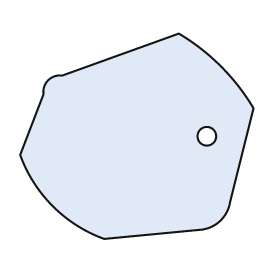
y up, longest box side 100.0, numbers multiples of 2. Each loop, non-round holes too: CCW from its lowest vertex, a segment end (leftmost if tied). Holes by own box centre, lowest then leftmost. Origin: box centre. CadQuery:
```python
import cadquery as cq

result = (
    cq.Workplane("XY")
    .moveTo(-14.0, -44.0)
    .lineTo(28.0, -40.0)
    .threePointArc((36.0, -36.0), (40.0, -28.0))
    .lineTo(50.0, 12.0)
    .threePointArc((36.0, 30.0), (18.0, 44.0))
    .lineTo(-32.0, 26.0)
    .threePointArc((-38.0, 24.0), (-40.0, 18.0))
    .lineTo(-50.0, -8.0)
    .threePointArc((-36.0, -30.0), (-14.0, -44.0))
    .close()
    .moveTo(30.0, 0.0)
    .circle(4.0)
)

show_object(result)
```